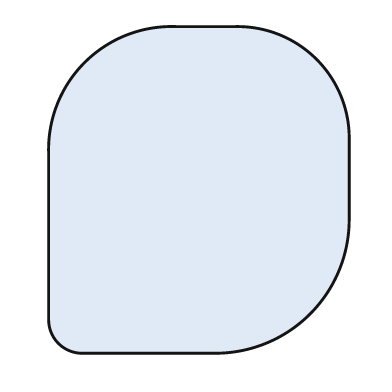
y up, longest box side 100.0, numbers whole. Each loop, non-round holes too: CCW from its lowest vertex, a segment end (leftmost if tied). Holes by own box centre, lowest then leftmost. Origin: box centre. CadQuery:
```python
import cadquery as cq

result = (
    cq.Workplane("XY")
    .moveTo(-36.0, -50.0)
    .lineTo(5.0, -50.0)
    .threePointArc((34.0, -38.0), (46.0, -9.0))
    .lineTo(46.0, 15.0)
    .threePointArc((36.0, 40.0), (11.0, 50.0))
    .lineTo(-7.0, 50.0)
    .threePointArc((-35.0, 39.0), (-46.0, 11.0))
    .lineTo(-46.0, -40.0)
    .threePointArc((-43.0, -47.0), (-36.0, -50.0))
    .close()
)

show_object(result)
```